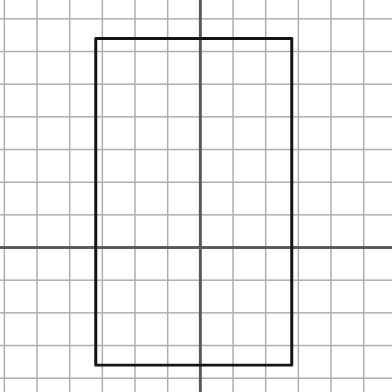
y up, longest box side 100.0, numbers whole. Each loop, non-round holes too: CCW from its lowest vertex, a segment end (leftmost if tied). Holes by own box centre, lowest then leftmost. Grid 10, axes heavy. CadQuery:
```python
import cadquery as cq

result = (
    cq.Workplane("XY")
    .moveTo(-32.0, -36.0)
    .lineTo(28.0, -36.0)
    .lineTo(28.0, 64.0)
    .lineTo(-32.0, 64.0)
    .close()
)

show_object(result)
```